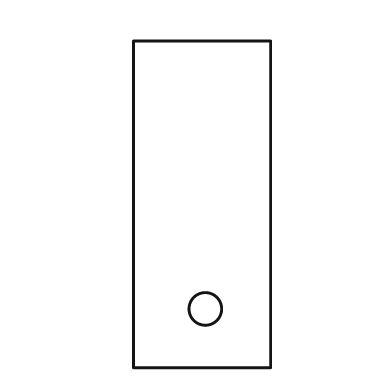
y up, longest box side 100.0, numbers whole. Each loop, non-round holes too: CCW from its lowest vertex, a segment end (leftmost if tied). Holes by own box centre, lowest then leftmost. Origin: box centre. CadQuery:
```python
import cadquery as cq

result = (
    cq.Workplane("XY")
    .moveTo(-21.0, -50.0)
    .lineTo(21.0, -50.0)
    .lineTo(21.0, 50.0)
    .lineTo(-21.0, 50.0)
    .close()
    .moveTo(1.0, -32.0)
    .circle(5.0)
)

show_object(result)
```